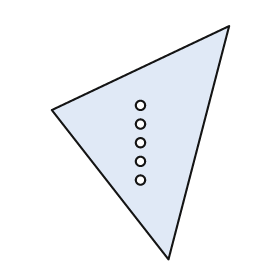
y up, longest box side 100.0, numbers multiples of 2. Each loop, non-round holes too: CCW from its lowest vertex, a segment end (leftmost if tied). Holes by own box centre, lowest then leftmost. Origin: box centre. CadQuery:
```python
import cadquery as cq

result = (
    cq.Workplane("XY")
    .moveTo(12.0, -50.0)
    .lineTo(38.0, 50.0)
    .lineTo(-38.0, 14.0)
    .close()
    .moveTo(0.0, -16.0)
    .circle(2.0)
    .moveTo(0.0, -8.0)
    .circle(2.0)
    .moveTo(0.0, 0.0)
    .circle(2.0)
    .moveTo(0.0, 8.0)
    .circle(2.0)
    .moveTo(0.0, 16.0)
    .circle(2.0)
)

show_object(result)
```